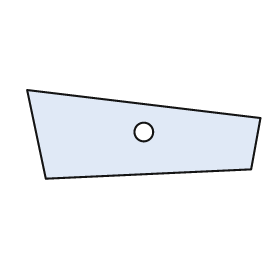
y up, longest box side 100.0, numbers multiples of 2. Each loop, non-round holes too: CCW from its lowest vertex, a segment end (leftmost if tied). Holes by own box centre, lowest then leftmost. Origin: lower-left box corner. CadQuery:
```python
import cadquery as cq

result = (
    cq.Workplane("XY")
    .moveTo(8.0, 0.0)
    .lineTo(96.0, 4.0)
    .lineTo(100.0, 26.0)
    .lineTo(0.0, 38.0)
    .close()
    .moveTo(50.0, 20.0)
    .circle(4.0)
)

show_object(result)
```